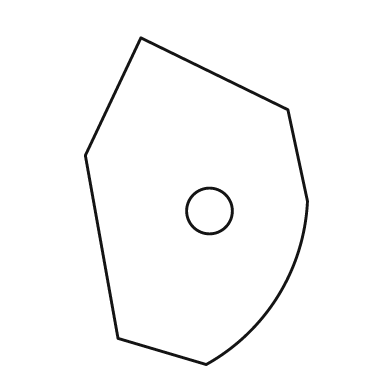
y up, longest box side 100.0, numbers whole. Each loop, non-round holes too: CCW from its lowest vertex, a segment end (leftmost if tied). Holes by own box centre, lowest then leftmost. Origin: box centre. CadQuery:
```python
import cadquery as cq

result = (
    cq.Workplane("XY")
    .moveTo(3.0, -50.0)
    .threePointArc((25.0, -29.0), (34.0, 0.0))
    .lineTo(28.0, 28.0)
    .lineTo(-17.0, 50.0)
    .lineTo(-34.0, 14.0)
    .lineTo(-24.0, -42.0)
    .close()
    .moveTo(4.0, -3.0)
    .circle(7.0)
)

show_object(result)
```